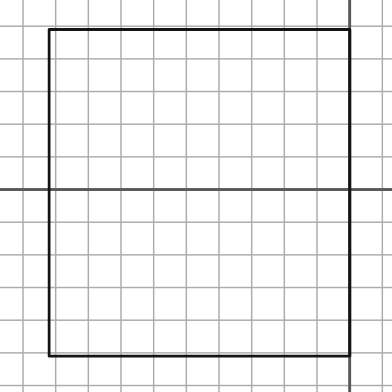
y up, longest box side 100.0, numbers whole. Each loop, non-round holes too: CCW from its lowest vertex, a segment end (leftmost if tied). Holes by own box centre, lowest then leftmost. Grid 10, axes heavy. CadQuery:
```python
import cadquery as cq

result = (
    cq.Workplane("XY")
    .moveTo(-92.0, -51.0)
    .lineTo(0.0, -51.0)
    .lineTo(0.0, 49.0)
    .lineTo(-92.0, 49.0)
    .close()
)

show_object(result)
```